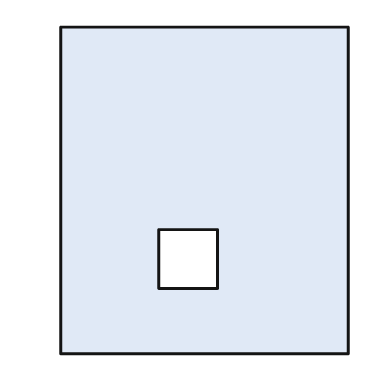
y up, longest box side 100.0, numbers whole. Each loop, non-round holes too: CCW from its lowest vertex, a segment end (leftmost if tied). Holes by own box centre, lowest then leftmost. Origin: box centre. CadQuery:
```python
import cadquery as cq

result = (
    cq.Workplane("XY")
    .moveTo(-44.0, -50.0)
    .lineTo(44.0, -50.0)
    .lineTo(44.0, 50.0)
    .lineTo(-44.0, 50.0)
    .close()
    .moveTo(-14.0, -30.0)
    .lineTo(4.0, -30.0)
    .lineTo(4.0, -12.0)
    .lineTo(-14.0, -12.0)
    .close()
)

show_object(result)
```